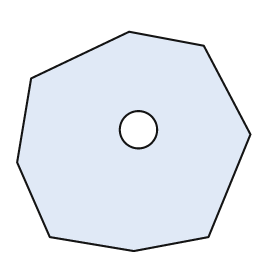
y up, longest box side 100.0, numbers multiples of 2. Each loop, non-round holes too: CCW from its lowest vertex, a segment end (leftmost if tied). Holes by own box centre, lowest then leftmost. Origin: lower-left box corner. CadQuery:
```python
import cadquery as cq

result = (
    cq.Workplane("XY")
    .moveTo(50.0, 0.0)
    .lineTo(82.0, 6.0)
    .lineTo(100.0, 50.0)
    .lineTo(80.0, 88.0)
    .lineTo(48.0, 94.0)
    .lineTo(6.0, 74.0)
    .lineTo(0.0, 38.0)
    .lineTo(14.0, 6.0)
    .close()
    .moveTo(52.0, 52.0)
    .circle(8.0)
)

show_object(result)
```